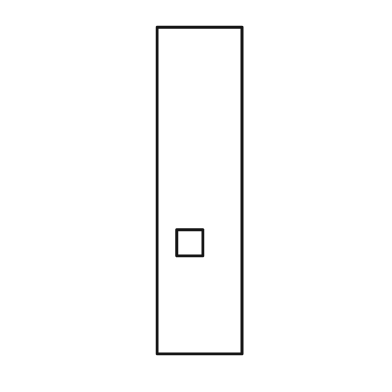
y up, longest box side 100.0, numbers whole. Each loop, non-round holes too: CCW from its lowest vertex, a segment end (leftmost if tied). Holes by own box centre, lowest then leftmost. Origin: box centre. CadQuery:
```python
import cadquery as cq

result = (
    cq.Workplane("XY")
    .moveTo(-13.0, -50.0)
    .lineTo(13.0, -50.0)
    .lineTo(13.0, 50.0)
    .lineTo(-13.0, 50.0)
    .close()
    .moveTo(-7.0, -20.0)
    .lineTo(1.0, -20.0)
    .lineTo(1.0, -12.0)
    .lineTo(-7.0, -12.0)
    .close()
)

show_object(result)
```